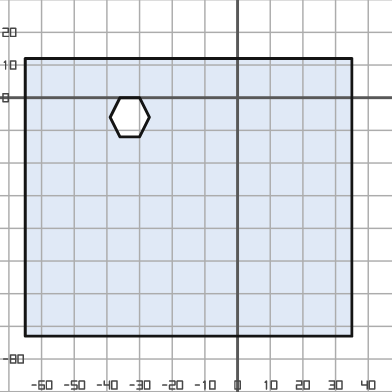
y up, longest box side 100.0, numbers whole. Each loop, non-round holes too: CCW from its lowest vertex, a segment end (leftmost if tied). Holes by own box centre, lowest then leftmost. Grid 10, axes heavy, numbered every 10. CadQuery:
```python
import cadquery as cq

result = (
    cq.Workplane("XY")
    .moveTo(-65.0, -73.0)
    .lineTo(35.0, -73.0)
    .lineTo(35.0, 12.0)
    .lineTo(-65.0, 12.0)
    .close()
    .moveTo(-36.0, -12.0)
    .lineTo(-30.0, -12.0)
    .lineTo(-27.0, -6.0)
    .lineTo(-30.0, 0.0)
    .lineTo(-36.0, 0.0)
    .lineTo(-39.0, -6.0)
    .close()
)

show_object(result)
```